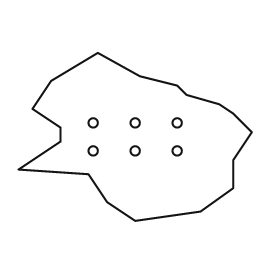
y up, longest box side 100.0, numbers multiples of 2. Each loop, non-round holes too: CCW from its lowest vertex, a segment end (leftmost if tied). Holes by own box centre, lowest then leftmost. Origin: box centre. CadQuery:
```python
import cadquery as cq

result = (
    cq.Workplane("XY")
    .moveTo(0.0, -36.0)
    .lineTo(28.0, -32.0)
    .lineTo(42.0, -22.0)
    .lineTo(42.0, -10.0)
    .lineTo(50.0, 2.0)
    .lineTo(42.0, 10.0)
    .lineTo(36.0, 14.0)
    .lineTo(22.0, 18.0)
    .lineTo(18.0, 22.0)
    .lineTo(2.0, 26.0)
    .lineTo(-16.0, 36.0)
    .lineTo(-36.0, 24.0)
    .lineTo(-44.0, 12.0)
    .lineTo(-32.0, 4.0)
    .lineTo(-32.0, -2.0)
    .lineTo(-50.0, -14.0)
    .lineTo(-20.0, -16.0)
    .lineTo(-12.0, -28.0)
    .close()
    .moveTo(-18.0, -6.0)
    .circle(2.0)
    .moveTo(0.0, -6.0)
    .circle(2.0)
    .moveTo(18.0, -6.0)
    .circle(2.0)
    .moveTo(-18.0, 6.0)
    .circle(2.0)
    .moveTo(0.0, 6.0)
    .circle(2.0)
    .moveTo(18.0, 6.0)
    .circle(2.0)
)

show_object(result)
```